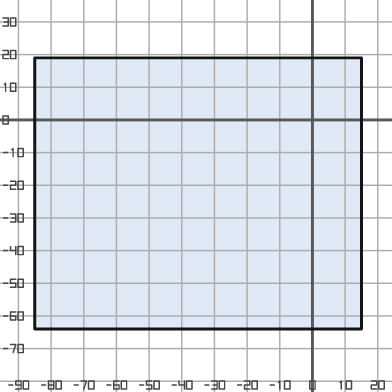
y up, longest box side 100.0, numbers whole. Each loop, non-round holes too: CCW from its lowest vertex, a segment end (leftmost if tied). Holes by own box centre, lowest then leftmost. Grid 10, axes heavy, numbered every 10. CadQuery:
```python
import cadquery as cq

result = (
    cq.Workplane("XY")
    .moveTo(-85.0, -64.0)
    .lineTo(15.0, -64.0)
    .lineTo(15.0, 19.0)
    .lineTo(-85.0, 19.0)
    .close()
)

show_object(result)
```